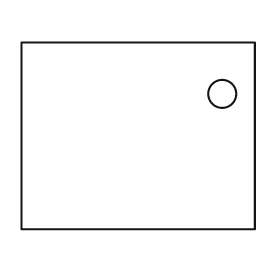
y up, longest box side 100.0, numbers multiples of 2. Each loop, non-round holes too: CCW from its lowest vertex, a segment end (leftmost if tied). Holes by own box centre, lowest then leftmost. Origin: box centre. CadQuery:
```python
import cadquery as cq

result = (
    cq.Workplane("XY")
    .moveTo(-50.0, -40.0)
    .lineTo(50.0, -40.0)
    .lineTo(50.0, 40.0)
    .lineTo(-50.0, 40.0)
    .close()
    .moveTo(36.0, 18.0)
    .circle(6.0)
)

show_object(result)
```